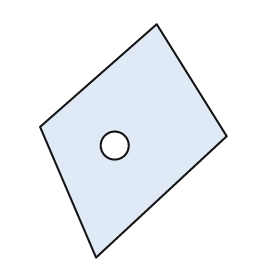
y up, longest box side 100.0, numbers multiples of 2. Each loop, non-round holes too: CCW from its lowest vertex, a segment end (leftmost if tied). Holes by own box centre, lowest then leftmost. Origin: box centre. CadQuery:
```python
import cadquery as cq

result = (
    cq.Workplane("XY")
    .moveTo(-16.0, -50.0)
    .lineTo(40.0, 2.0)
    .lineTo(10.0, 50.0)
    .lineTo(-40.0, 6.0)
    .close()
    .moveTo(-8.0, -2.0)
    .circle(6.0)
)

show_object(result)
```